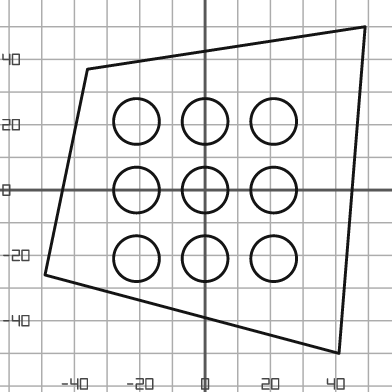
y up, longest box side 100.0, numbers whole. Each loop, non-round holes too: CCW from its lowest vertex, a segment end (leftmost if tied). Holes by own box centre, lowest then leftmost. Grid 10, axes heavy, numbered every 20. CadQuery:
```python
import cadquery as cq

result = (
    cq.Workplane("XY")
    .moveTo(41.0, -50.0)
    .lineTo(49.0, 50.0)
    .lineTo(-36.0, 37.0)
    .lineTo(-49.0, -26.0)
    .close()
    .moveTo(-21.0, -21.0)
    .circle(7.0)
    .moveTo(0.0, -21.0)
    .circle(7.0)
    .moveTo(21.0, -21.0)
    .circle(7.0)
    .moveTo(-21.0, 0.0)
    .circle(7.0)
    .moveTo(0.0, 0.0)
    .circle(7.0)
    .moveTo(21.0, 0.0)
    .circle(7.0)
    .moveTo(-21.0, 21.0)
    .circle(7.0)
    .moveTo(0.0, 21.0)
    .circle(7.0)
    .moveTo(21.0, 21.0)
    .circle(7.0)
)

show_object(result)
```